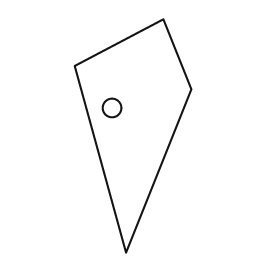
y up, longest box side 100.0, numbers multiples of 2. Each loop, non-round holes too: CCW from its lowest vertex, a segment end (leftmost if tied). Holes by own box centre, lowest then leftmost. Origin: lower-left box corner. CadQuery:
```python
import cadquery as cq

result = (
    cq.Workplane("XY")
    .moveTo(22.0, 0.0)
    .lineTo(50.0, 70.0)
    .lineTo(38.0, 100.0)
    .lineTo(0.0, 80.0)
    .close()
    .moveTo(16.0, 62.0)
    .circle(4.0)
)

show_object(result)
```